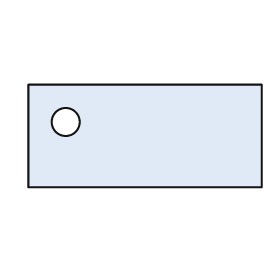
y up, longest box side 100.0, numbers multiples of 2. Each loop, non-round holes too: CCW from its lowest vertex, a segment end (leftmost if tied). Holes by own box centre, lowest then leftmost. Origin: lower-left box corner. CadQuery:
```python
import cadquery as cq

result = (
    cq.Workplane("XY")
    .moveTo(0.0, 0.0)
    .lineTo(100.0, 0.0)
    .lineTo(100.0, 44.0)
    .lineTo(0.0, 44.0)
    .close()
    .moveTo(16.0, 28.0)
    .circle(6.0)
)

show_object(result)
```